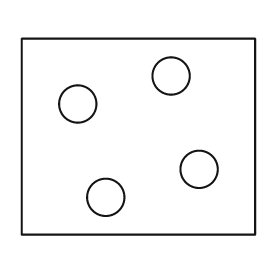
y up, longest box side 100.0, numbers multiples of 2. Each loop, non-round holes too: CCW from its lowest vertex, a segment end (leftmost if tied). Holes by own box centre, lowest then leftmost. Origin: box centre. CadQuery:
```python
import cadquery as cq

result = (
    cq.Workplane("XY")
    .moveTo(-50.0, -42.0)
    .lineTo(50.0, -42.0)
    .lineTo(50.0, 42.0)
    .lineTo(-50.0, 42.0)
    .close()
    .moveTo(-14.0, -26.0)
    .circle(8.0)
    .moveTo(26.0, -14.0)
    .circle(8.0)
    .moveTo(-26.0, 14.0)
    .circle(8.0)
    .moveTo(14.0, 26.0)
    .circle(8.0)
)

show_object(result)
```